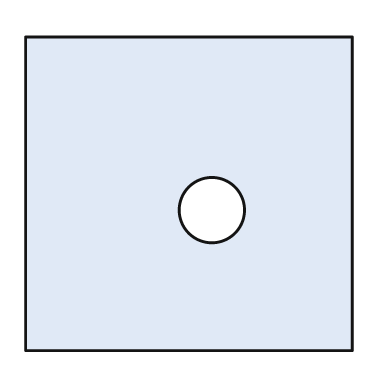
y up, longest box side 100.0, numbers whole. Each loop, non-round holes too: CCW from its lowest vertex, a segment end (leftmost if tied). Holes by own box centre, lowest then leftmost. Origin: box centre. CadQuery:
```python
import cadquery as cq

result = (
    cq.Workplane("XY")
    .moveTo(-50.0, -48.0)
    .lineTo(50.0, -48.0)
    .lineTo(50.0, 48.0)
    .lineTo(-50.0, 48.0)
    .close()
    .moveTo(7.0, -5.0)
    .circle(10.0)
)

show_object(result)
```